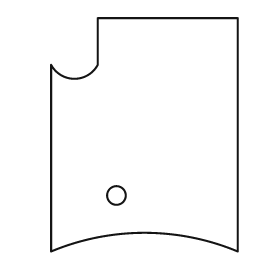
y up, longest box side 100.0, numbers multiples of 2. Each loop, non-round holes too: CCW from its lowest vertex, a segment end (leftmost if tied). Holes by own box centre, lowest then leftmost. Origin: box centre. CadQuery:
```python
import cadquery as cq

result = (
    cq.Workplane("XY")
    .moveTo(-40.0, -50.0)
    .threePointArc((0.0, -42.0), (40.0, -50.0))
    .lineTo(40.0, 50.0)
    .lineTo(-20.0, 50.0)
    .lineTo(-20.0, 30.0)
    .threePointArc((-30.0, 24.0), (-40.0, 30.0))
    .close()
    .moveTo(-12.0, -26.0)
    .circle(4.0)
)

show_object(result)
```